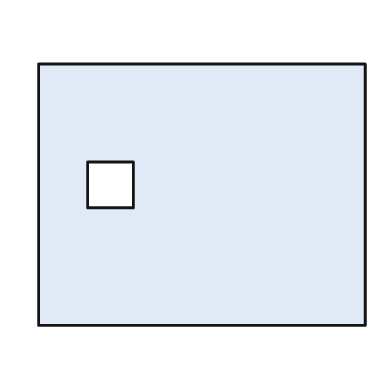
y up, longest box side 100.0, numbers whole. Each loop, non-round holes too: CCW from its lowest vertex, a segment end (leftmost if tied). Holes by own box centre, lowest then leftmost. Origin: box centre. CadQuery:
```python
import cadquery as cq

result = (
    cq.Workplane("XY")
    .moveTo(-50.0, -40.0)
    .lineTo(50.0, -40.0)
    .lineTo(50.0, 40.0)
    .lineTo(-50.0, 40.0)
    .close()
    .moveTo(-35.0, -4.0)
    .lineTo(-21.0, -4.0)
    .lineTo(-21.0, 10.0)
    .lineTo(-35.0, 10.0)
    .close()
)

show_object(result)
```